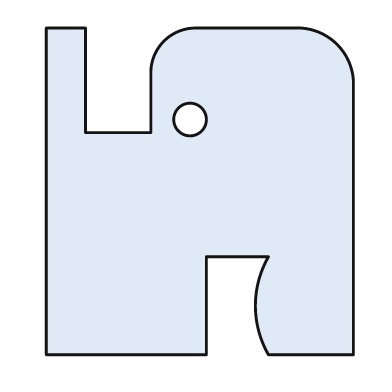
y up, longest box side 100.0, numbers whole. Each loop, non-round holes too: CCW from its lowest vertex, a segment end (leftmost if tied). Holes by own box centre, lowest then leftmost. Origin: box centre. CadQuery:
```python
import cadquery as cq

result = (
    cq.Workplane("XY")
    .moveTo(-47.0, -50.0)
    .lineTo(2.0, -50.0)
    .lineTo(2.0, -20.0)
    .lineTo(21.0, -20.0)
    .threePointArc((17.0, -35.0), (21.0, -50.0))
    .lineTo(47.0, -50.0)
    .lineTo(47.0, 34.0)
    .threePointArc((42.0, 45.0), (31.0, 50.0))
    .lineTo(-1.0, 50.0)
    .threePointArc((-11.0, 46.0), (-15.0, 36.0))
    .lineTo(-15.0, 18.0)
    .lineTo(-35.0, 18.0)
    .lineTo(-35.0, 50.0)
    .lineTo(-47.0, 50.0)
    .close()
    .moveTo(-3.0, 22.0)
    .circle(5.0)
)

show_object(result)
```